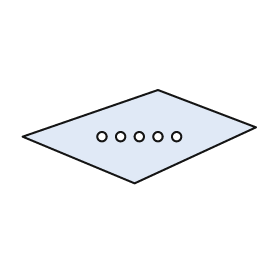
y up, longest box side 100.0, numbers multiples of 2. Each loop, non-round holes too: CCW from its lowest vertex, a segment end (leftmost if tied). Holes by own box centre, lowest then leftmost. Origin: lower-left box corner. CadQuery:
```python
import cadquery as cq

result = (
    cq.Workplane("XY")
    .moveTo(48.0, 0.0)
    .lineTo(100.0, 24.0)
    .lineTo(58.0, 40.0)
    .lineTo(0.0, 20.0)
    .close()
    .moveTo(34.0, 20.0)
    .circle(2.0)
    .moveTo(42.0, 20.0)
    .circle(2.0)
    .moveTo(50.0, 20.0)
    .circle(2.0)
    .moveTo(58.0, 20.0)
    .circle(2.0)
    .moveTo(66.0, 20.0)
    .circle(2.0)
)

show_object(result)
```